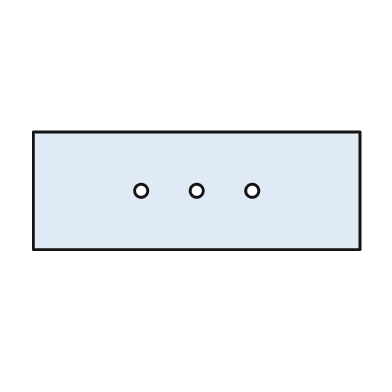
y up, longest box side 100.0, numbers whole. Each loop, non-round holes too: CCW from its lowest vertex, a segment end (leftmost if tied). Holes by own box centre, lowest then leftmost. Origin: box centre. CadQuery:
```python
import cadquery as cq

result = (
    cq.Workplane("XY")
    .moveTo(-50.0, -18.0)
    .lineTo(50.0, -18.0)
    .lineTo(50.0, 18.0)
    .lineTo(-50.0, 18.0)
    .close()
    .moveTo(-17.0, 0.0)
    .circle(2.0)
    .moveTo(0.0, 0.0)
    .circle(2.0)
    .moveTo(17.0, 0.0)
    .circle(2.0)
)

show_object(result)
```